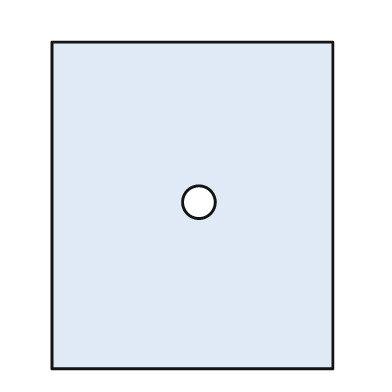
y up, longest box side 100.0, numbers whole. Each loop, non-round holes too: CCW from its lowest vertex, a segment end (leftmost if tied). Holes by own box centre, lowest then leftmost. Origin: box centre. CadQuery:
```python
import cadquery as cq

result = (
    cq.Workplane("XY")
    .moveTo(-43.0, -50.0)
    .lineTo(43.0, -50.0)
    .lineTo(43.0, 50.0)
    .lineTo(-43.0, 50.0)
    .close()
    .moveTo(2.0, 1.0)
    .circle(5.0)
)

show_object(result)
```